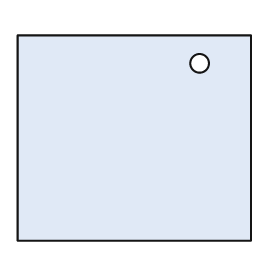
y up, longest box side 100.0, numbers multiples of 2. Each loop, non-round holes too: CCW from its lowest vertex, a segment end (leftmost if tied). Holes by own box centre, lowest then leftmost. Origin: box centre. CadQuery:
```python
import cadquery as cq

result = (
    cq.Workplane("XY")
    .moveTo(-50.0, -44.0)
    .lineTo(50.0, -44.0)
    .lineTo(50.0, 44.0)
    .lineTo(-50.0, 44.0)
    .close()
    .moveTo(28.0, 32.0)
    .circle(4.0)
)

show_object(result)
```